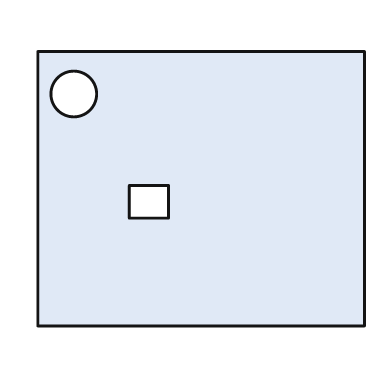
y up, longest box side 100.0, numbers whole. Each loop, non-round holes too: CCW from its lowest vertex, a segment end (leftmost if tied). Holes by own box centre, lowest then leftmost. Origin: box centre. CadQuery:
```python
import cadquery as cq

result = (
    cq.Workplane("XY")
    .moveTo(-50.0, -42.0)
    .lineTo(50.0, -42.0)
    .lineTo(50.0, 42.0)
    .lineTo(-50.0, 42.0)
    .close()
    .moveTo(-22.0, -9.0)
    .lineTo(-10.0, -9.0)
    .lineTo(-10.0, 1.0)
    .lineTo(-22.0, 1.0)
    .close()
    .moveTo(-39.0, 29.0)
    .circle(7.0)
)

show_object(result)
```